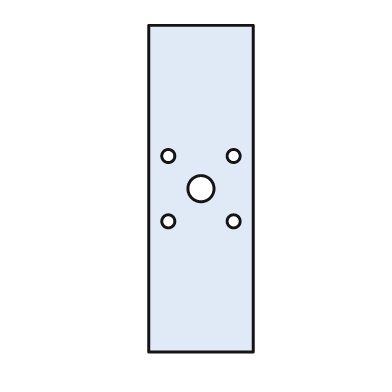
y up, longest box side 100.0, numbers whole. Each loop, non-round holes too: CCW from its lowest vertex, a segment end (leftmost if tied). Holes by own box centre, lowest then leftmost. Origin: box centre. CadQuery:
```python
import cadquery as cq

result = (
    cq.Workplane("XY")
    .moveTo(-16.0, -50.0)
    .lineTo(16.0, -50.0)
    .lineTo(16.0, 50.0)
    .lineTo(-16.0, 50.0)
    .close()
    .moveTo(-10.0, -10.0)
    .circle(2.0)
    .moveTo(10.0, -10.0)
    .circle(2.0)
    .moveTo(0.0, 0.0)
    .circle(4.0)
    .moveTo(-10.0, 10.0)
    .circle(2.0)
    .moveTo(10.0, 10.0)
    .circle(2.0)
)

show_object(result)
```